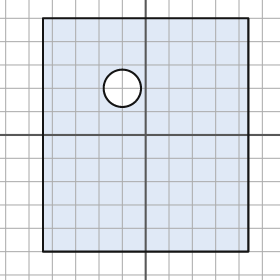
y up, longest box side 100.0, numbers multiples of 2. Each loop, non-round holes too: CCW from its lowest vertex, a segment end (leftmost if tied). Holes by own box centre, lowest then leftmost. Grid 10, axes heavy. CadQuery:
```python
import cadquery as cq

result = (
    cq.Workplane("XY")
    .moveTo(-44.0, -50.0)
    .lineTo(44.0, -50.0)
    .lineTo(44.0, 50.0)
    .lineTo(-44.0, 50.0)
    .close()
    .moveTo(-10.0, 20.0)
    .circle(8.0)
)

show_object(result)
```